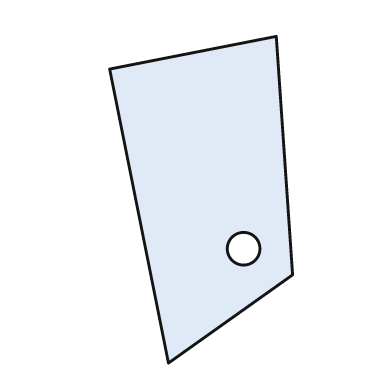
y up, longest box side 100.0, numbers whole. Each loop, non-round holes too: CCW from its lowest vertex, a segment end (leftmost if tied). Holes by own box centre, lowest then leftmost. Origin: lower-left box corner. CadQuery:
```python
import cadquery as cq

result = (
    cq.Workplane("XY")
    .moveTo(18.0, 0.0)
    .lineTo(56.0, 27.0)
    .lineTo(51.0, 100.0)
    .lineTo(0.0, 90.0)
    .close()
    .moveTo(41.0, 35.0)
    .circle(5.0)
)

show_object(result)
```